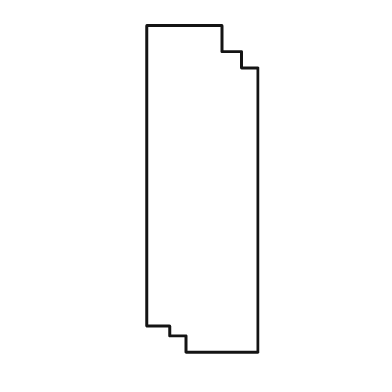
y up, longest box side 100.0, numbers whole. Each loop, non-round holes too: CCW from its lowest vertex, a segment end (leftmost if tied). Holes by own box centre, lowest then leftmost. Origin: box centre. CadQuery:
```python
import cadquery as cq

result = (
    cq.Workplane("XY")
    .moveTo(-5.0, -50.0)
    .lineTo(17.0, -50.0)
    .lineTo(17.0, 37.0)
    .lineTo(12.0, 37.0)
    .lineTo(12.0, 42.0)
    .lineTo(6.0, 42.0)
    .lineTo(6.0, 50.0)
    .lineTo(-17.0, 50.0)
    .lineTo(-17.0, -42.0)
    .lineTo(-10.0, -42.0)
    .lineTo(-10.0, -45.0)
    .lineTo(-5.0, -45.0)
    .close()
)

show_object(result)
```